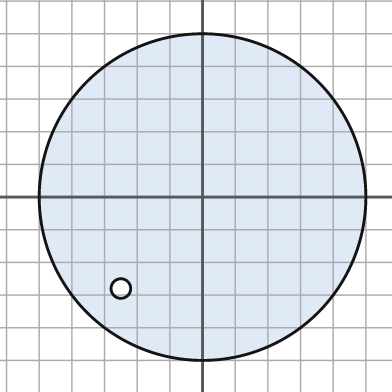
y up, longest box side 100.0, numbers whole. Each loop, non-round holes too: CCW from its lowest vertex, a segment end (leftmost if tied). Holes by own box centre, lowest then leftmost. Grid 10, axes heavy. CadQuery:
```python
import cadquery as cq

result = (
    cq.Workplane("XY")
    .moveTo(0.0, 0.0)
    .circle(50.0)
    .moveTo(-25.0, -28.0)
    .circle(3.0)
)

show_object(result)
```